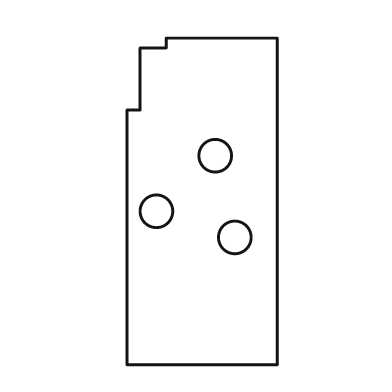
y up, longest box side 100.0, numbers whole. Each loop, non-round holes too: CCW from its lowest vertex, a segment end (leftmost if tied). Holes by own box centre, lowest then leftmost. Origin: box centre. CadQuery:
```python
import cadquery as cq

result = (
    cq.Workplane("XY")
    .moveTo(-23.0, -50.0)
    .lineTo(23.0, -50.0)
    .lineTo(23.0, 50.0)
    .lineTo(-11.0, 50.0)
    .lineTo(-11.0, 47.0)
    .lineTo(-19.0, 47.0)
    .lineTo(-19.0, 28.0)
    .lineTo(-23.0, 28.0)
    .close()
    .moveTo(10.0, -11.0)
    .circle(5.0)
    .moveTo(-14.0, -3.0)
    .circle(5.0)
    .moveTo(4.0, 14.0)
    .circle(5.0)
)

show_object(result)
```